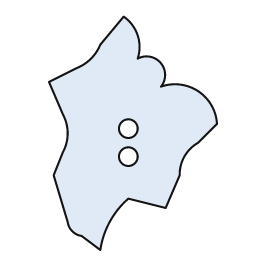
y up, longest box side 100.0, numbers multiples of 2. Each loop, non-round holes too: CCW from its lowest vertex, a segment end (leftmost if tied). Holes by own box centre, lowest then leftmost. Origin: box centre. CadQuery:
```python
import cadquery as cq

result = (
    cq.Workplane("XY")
    .moveTo(-14.0, -50.0)
    .threePointArc((-10.0, -38.0), (-2.0, -28.0))
    .lineTo(14.0, -32.0)
    .lineTo(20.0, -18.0)
    .threePointArc((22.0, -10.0), (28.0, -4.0))
    .lineTo(36.0, 4.0)
    .threePointArc((28.0, 18.0), (12.0, 20.0))
    .threePointArc((12.0, 30.0), (2.0, 32.0))
    .threePointArc((2.0, 42.0), (-4.0, 50.0))
    .lineTo(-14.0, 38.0)
    .threePointArc((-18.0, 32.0), (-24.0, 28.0))
    .lineTo(-36.0, 22.0)
    .lineTo(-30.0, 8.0)
    .threePointArc((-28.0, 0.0), (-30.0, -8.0))
    .lineTo(-34.0, -18.0)
    .lineTo(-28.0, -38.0)
    .threePointArc((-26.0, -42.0), (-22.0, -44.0))
    .close()
    .moveTo(-2.0, -10.0)
    .circle(4.0)
    .moveTo(-2.0, 2.0)
    .circle(4.0)
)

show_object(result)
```